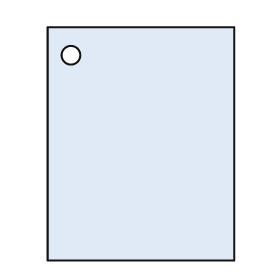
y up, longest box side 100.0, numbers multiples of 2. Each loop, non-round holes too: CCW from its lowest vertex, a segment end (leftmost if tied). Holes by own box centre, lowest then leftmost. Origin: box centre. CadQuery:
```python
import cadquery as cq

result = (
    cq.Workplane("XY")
    .moveTo(-40.0, -50.0)
    .lineTo(40.0, -50.0)
    .lineTo(40.0, 50.0)
    .lineTo(-40.0, 50.0)
    .close()
    .moveTo(-30.0, 38.0)
    .circle(4.0)
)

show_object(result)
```